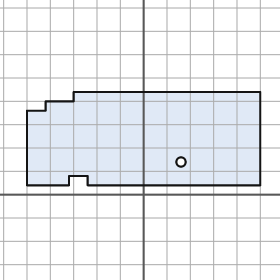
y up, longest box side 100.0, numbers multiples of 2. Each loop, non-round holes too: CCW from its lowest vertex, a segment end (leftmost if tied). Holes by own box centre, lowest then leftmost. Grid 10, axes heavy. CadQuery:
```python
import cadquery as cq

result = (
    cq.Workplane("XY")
    .moveTo(-50.0, 4.0)
    .lineTo(-32.0, 4.0)
    .lineTo(-32.0, 8.0)
    .lineTo(-24.0, 8.0)
    .lineTo(-24.0, 4.0)
    .lineTo(50.0, 4.0)
    .lineTo(50.0, 44.0)
    .lineTo(-30.0, 44.0)
    .lineTo(-30.0, 40.0)
    .lineTo(-42.0, 40.0)
    .lineTo(-42.0, 36.0)
    .lineTo(-50.0, 36.0)
    .close()
    .moveTo(16.0, 14.0)
    .circle(2.0)
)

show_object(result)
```